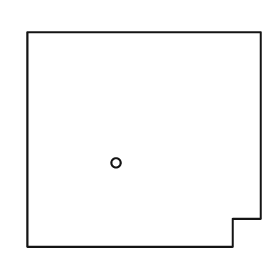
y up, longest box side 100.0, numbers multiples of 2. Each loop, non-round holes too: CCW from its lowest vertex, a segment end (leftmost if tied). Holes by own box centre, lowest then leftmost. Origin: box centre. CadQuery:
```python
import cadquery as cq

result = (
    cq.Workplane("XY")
    .moveTo(-50.0, -46.0)
    .lineTo(38.0, -46.0)
    .lineTo(38.0, -34.0)
    .lineTo(50.0, -34.0)
    .lineTo(50.0, 46.0)
    .lineTo(-50.0, 46.0)
    .close()
    .moveTo(-12.0, -10.0)
    .circle(2.0)
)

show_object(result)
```